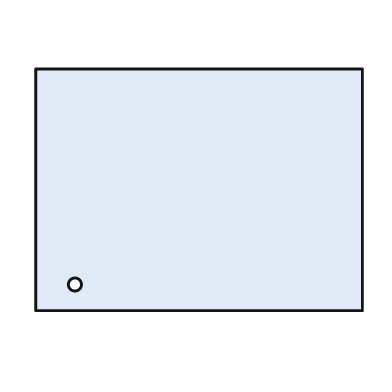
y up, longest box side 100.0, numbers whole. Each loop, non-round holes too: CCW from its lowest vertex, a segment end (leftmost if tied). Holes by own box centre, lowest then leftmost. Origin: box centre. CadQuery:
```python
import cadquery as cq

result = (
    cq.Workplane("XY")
    .moveTo(-50.0, -37.0)
    .lineTo(50.0, -37.0)
    .lineTo(50.0, 37.0)
    .lineTo(-50.0, 37.0)
    .close()
    .moveTo(-38.0, -29.0)
    .circle(2.0)
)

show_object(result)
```